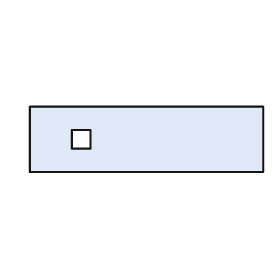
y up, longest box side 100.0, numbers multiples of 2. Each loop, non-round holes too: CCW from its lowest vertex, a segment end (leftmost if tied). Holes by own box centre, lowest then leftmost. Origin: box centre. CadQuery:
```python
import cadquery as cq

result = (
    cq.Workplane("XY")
    .moveTo(-50.0, -14.0)
    .lineTo(50.0, -14.0)
    .lineTo(50.0, 14.0)
    .lineTo(-50.0, 14.0)
    .close()
    .moveTo(-32.0, -4.0)
    .lineTo(-24.0, -4.0)
    .lineTo(-24.0, 4.0)
    .lineTo(-32.0, 4.0)
    .close()
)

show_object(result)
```